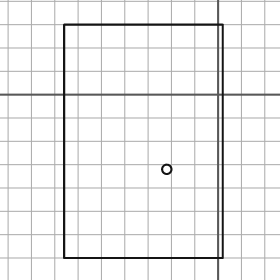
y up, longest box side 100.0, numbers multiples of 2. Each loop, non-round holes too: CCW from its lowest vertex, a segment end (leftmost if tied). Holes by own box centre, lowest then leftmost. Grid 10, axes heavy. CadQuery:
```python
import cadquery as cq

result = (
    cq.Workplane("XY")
    .moveTo(-66.0, -70.0)
    .lineTo(2.0, -70.0)
    .lineTo(2.0, 30.0)
    .lineTo(-66.0, 30.0)
    .close()
    .moveTo(-22.0, -32.0)
    .circle(2.0)
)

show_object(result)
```